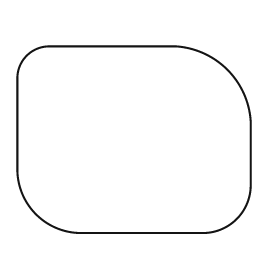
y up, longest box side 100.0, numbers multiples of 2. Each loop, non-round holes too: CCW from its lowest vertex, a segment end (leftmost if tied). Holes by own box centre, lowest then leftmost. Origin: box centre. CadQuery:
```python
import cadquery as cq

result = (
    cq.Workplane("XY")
    .moveTo(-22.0, -40.0)
    .lineTo(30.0, -40.0)
    .threePointArc((44.0, -34.0), (50.0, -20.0))
    .lineTo(50.0, 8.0)
    .threePointArc((40.0, 30.0), (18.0, 40.0))
    .lineTo(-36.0, 40.0)
    .threePointArc((-46.0, 36.0), (-50.0, 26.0))
    .lineTo(-50.0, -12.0)
    .threePointArc((-42.0, -32.0), (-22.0, -40.0))
    .close()
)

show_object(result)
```